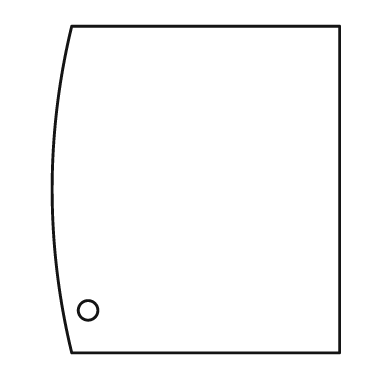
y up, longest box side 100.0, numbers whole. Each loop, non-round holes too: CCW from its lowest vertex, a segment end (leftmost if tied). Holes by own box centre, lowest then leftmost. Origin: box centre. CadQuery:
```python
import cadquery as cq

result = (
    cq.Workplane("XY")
    .moveTo(-38.0, -50.0)
    .lineTo(44.0, -50.0)
    .lineTo(44.0, 50.0)
    .lineTo(-38.0, 50.0)
    .threePointArc((-44.0, 0.0), (-38.0, -50.0))
    .close()
    .moveTo(-33.0, -37.0)
    .circle(3.0)
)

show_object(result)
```